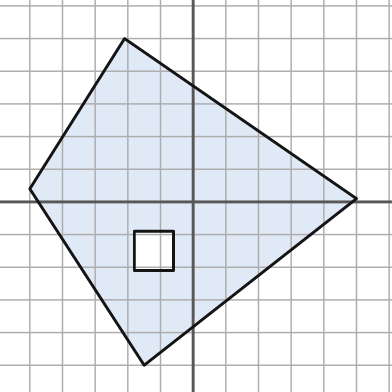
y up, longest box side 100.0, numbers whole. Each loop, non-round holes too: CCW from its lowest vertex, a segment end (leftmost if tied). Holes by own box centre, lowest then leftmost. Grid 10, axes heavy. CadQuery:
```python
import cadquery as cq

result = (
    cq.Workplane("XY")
    .moveTo(-15.0, -50.0)
    .lineTo(50.0, 1.0)
    .lineTo(-21.0, 50.0)
    .lineTo(-50.0, 4.0)
    .close()
    .moveTo(-18.0, -21.0)
    .lineTo(-6.0, -21.0)
    .lineTo(-6.0, -9.0)
    .lineTo(-18.0, -9.0)
    .close()
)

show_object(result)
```